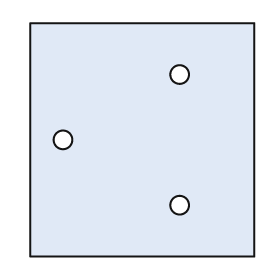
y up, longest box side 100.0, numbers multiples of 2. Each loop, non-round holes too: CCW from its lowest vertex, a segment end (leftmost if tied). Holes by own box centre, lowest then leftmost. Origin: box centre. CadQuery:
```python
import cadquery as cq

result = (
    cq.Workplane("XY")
    .moveTo(-48.0, -50.0)
    .lineTo(48.0, -50.0)
    .lineTo(48.0, 50.0)
    .lineTo(-48.0, 50.0)
    .close()
    .moveTo(16.0, -28.0)
    .circle(4.0)
    .moveTo(-34.0, 0.0)
    .circle(4.0)
    .moveTo(16.0, 28.0)
    .circle(4.0)
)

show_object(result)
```